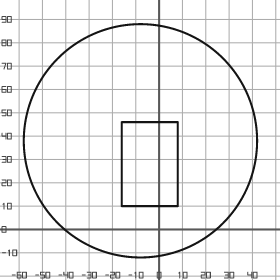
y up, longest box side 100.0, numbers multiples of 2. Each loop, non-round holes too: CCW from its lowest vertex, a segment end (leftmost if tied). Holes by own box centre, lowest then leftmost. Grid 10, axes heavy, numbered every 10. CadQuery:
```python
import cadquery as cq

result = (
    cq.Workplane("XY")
    .moveTo(-8.0, 38.0)
    .circle(50.0)
    .moveTo(-16.0, 10.0)
    .lineTo(8.0, 10.0)
    .lineTo(8.0, 46.0)
    .lineTo(-16.0, 46.0)
    .close()
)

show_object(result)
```